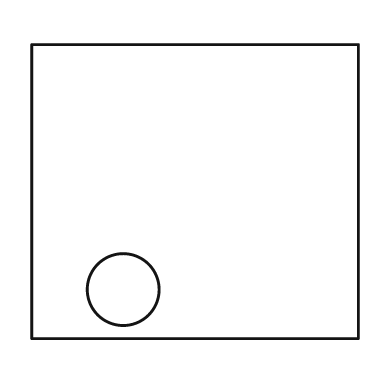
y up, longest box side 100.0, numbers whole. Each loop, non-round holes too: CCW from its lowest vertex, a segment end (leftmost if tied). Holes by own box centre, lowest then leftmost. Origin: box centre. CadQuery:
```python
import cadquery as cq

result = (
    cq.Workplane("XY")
    .moveTo(-50.0, -45.0)
    .lineTo(50.0, -45.0)
    .lineTo(50.0, 45.0)
    .lineTo(-50.0, 45.0)
    .close()
    .moveTo(-22.0, -30.0)
    .circle(11.0)
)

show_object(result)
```